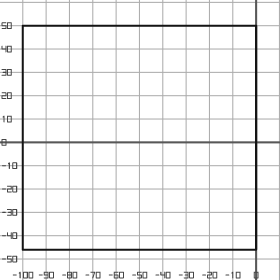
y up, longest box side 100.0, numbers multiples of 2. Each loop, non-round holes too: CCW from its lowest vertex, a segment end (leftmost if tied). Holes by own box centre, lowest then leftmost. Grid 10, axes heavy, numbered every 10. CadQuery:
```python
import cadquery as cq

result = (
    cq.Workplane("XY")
    .moveTo(-100.0, -46.0)
    .lineTo(0.0, -46.0)
    .lineTo(0.0, 50.0)
    .lineTo(-100.0, 50.0)
    .close()
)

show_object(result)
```